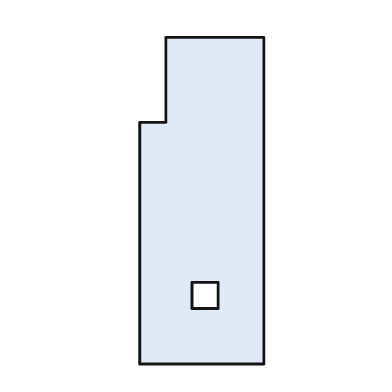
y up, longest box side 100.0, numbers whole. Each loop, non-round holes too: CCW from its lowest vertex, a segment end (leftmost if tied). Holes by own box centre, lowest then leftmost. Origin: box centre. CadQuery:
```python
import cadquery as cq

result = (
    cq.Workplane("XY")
    .moveTo(-19.0, -50.0)
    .lineTo(19.0, -50.0)
    .lineTo(19.0, 50.0)
    .lineTo(-11.0, 50.0)
    .lineTo(-11.0, 24.0)
    .lineTo(-19.0, 24.0)
    .close()
    .moveTo(-3.0, -33.0)
    .lineTo(5.0, -33.0)
    .lineTo(5.0, -25.0)
    .lineTo(-3.0, -25.0)
    .close()
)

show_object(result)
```